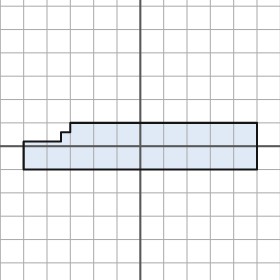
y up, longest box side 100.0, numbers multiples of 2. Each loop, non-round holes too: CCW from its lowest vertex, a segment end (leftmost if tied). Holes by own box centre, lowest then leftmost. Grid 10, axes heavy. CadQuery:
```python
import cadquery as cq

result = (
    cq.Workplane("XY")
    .moveTo(-50.0, -10.0)
    .lineTo(50.0, -10.0)
    .lineTo(50.0, 10.0)
    .lineTo(-30.0, 10.0)
    .lineTo(-30.0, 6.0)
    .lineTo(-34.0, 6.0)
    .lineTo(-34.0, 2.0)
    .lineTo(-50.0, 2.0)
    .close()
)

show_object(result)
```